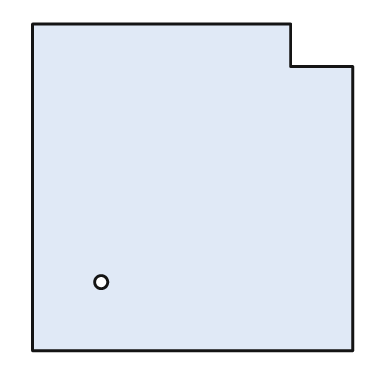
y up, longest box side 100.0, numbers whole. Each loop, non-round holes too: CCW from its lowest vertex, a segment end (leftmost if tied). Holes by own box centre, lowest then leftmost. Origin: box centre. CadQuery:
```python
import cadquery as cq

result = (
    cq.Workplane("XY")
    .moveTo(-49.0, -50.0)
    .lineTo(49.0, -50.0)
    .lineTo(49.0, 37.0)
    .lineTo(30.0, 37.0)
    .lineTo(30.0, 50.0)
    .lineTo(-49.0, 50.0)
    .close()
    .moveTo(-28.0, -29.0)
    .circle(2.0)
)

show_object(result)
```